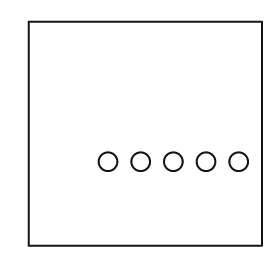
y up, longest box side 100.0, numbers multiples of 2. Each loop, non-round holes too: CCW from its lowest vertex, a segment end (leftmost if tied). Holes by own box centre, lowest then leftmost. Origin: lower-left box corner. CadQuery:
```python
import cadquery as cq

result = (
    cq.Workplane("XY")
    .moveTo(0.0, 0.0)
    .lineTo(100.0, 0.0)
    .lineTo(100.0, 96.0)
    .lineTo(0.0, 96.0)
    .close()
    .moveTo(34.0, 36.0)
    .circle(4.0)
    .moveTo(48.0, 36.0)
    .circle(4.0)
    .moveTo(62.0, 36.0)
    .circle(4.0)
    .moveTo(76.0, 36.0)
    .circle(4.0)
    .moveTo(90.0, 36.0)
    .circle(4.0)
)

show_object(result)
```